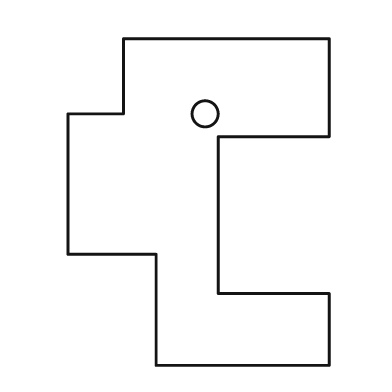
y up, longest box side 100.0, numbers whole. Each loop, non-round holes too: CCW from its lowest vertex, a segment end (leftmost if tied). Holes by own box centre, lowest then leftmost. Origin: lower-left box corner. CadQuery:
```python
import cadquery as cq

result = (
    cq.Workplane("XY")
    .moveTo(27.0, 0.0)
    .lineTo(80.0, 0.0)
    .lineTo(80.0, 22.0)
    .lineTo(46.0, 22.0)
    .lineTo(46.0, 70.0)
    .lineTo(80.0, 70.0)
    .lineTo(80.0, 100.0)
    .lineTo(17.0, 100.0)
    .lineTo(17.0, 77.0)
    .lineTo(0.0, 77.0)
    .lineTo(0.0, 34.0)
    .lineTo(27.0, 34.0)
    .close()
    .moveTo(42.0, 77.0)
    .circle(4.0)
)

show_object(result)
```